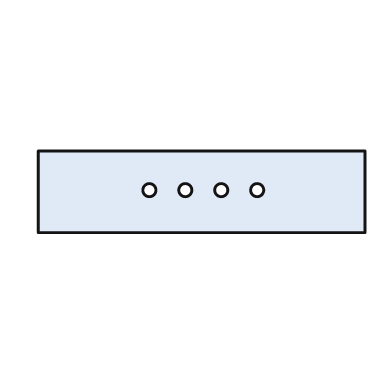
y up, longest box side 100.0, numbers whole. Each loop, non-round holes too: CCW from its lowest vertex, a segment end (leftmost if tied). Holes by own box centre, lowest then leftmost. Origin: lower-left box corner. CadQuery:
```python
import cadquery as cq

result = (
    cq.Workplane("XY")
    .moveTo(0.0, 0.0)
    .lineTo(100.0, 0.0)
    .lineTo(100.0, 25.0)
    .lineTo(0.0, 25.0)
    .close()
    .moveTo(34.0, 13.0)
    .circle(2.0)
    .moveTo(45.0, 13.0)
    .circle(2.0)
    .moveTo(56.0, 13.0)
    .circle(2.0)
    .moveTo(67.0, 13.0)
    .circle(2.0)
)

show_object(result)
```